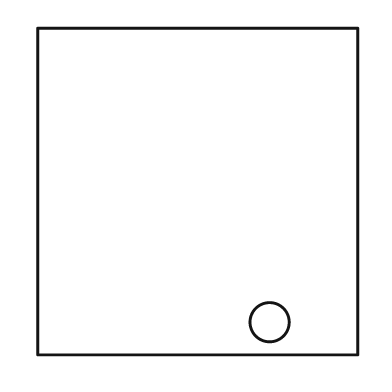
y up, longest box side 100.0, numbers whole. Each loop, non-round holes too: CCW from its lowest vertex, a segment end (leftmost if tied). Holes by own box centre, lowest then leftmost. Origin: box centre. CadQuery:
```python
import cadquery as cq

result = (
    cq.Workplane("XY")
    .moveTo(-49.0, -50.0)
    .lineTo(49.0, -50.0)
    .lineTo(49.0, 50.0)
    .lineTo(-49.0, 50.0)
    .close()
    .moveTo(22.0, -40.0)
    .circle(6.0)
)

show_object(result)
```